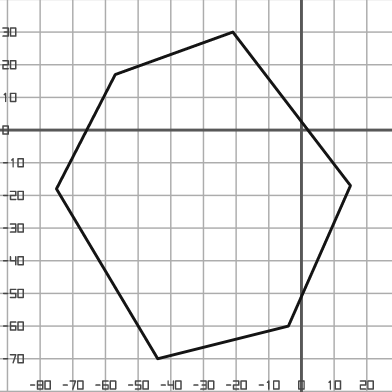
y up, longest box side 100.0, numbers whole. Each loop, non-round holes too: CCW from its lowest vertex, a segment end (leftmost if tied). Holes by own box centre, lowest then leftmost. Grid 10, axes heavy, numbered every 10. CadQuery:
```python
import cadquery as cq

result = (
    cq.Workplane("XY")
    .moveTo(-44.0, -70.0)
    .lineTo(-4.0, -60.0)
    .lineTo(15.0, -17.0)
    .lineTo(-21.0, 30.0)
    .lineTo(-57.0, 17.0)
    .lineTo(-75.0, -18.0)
    .close()
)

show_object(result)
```